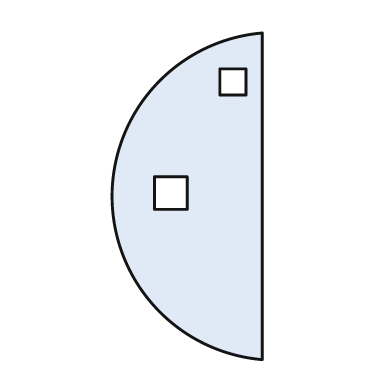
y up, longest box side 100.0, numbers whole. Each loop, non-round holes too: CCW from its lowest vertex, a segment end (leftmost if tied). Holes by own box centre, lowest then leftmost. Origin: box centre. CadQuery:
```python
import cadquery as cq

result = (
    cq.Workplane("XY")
    .moveTo(23.0, -50.0)
    .lineTo(23.0, 50.0)
    .threePointArc((-23.0, 0.0), (23.0, -50.0))
    .close()
    .moveTo(-10.0, -4.0)
    .lineTo(0.0, -4.0)
    .lineTo(0.0, 6.0)
    .lineTo(-10.0, 6.0)
    .close()
    .moveTo(10.0, 31.0)
    .lineTo(18.0, 31.0)
    .lineTo(18.0, 39.0)
    .lineTo(10.0, 39.0)
    .close()
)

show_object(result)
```